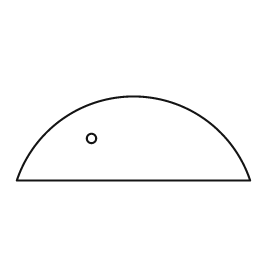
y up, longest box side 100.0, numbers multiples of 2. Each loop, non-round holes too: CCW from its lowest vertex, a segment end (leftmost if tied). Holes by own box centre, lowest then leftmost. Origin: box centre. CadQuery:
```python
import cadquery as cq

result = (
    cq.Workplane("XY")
    .moveTo(-50.0, -18.0)
    .lineTo(50.0, -18.0)
    .threePointArc((0.0, 18.0), (-50.0, -18.0))
    .close()
    .moveTo(-18.0, 0.0)
    .circle(2.0)
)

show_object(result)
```